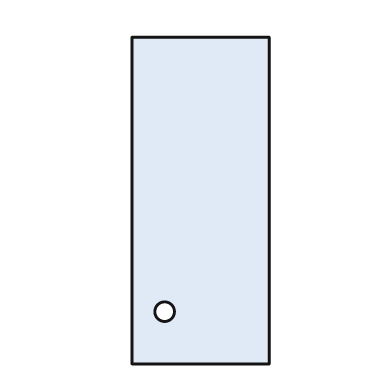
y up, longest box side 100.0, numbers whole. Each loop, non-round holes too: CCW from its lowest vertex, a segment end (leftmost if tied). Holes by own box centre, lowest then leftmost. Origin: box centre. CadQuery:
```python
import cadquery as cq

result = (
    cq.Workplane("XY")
    .moveTo(-21.0, -50.0)
    .lineTo(21.0, -50.0)
    .lineTo(21.0, 50.0)
    .lineTo(-21.0, 50.0)
    .close()
    .moveTo(-11.0, -34.0)
    .circle(3.0)
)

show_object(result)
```